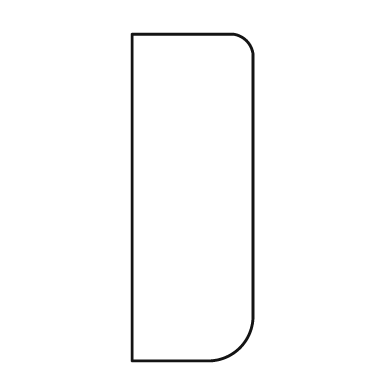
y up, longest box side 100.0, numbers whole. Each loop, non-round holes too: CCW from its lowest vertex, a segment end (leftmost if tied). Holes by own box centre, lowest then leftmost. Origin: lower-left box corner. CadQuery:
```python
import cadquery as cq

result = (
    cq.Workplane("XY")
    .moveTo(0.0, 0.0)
    .lineTo(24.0, 0.0)
    .threePointArc((33.0, 4.0), (37.0, 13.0))
    .lineTo(37.0, 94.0)
    .threePointArc((35.0, 98.0), (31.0, 100.0))
    .lineTo(0.0, 100.0)
    .close()
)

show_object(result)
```